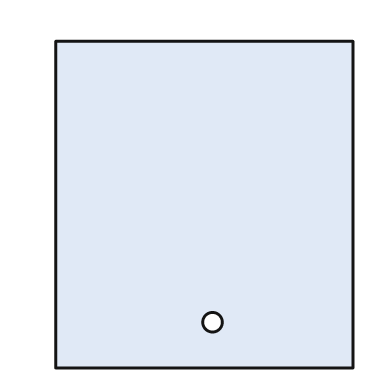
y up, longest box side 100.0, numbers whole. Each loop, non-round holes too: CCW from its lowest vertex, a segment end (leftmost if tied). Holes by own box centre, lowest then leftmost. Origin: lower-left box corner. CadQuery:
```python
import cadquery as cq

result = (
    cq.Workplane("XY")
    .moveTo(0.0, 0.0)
    .lineTo(91.0, 0.0)
    .lineTo(91.0, 100.0)
    .lineTo(0.0, 100.0)
    .close()
    .moveTo(48.0, 14.0)
    .circle(3.0)
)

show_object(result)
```